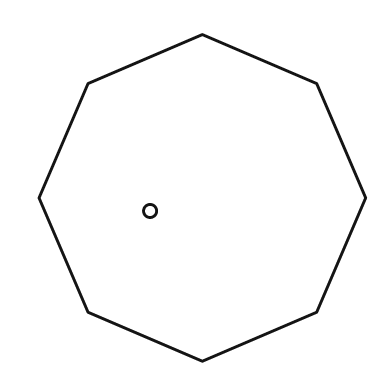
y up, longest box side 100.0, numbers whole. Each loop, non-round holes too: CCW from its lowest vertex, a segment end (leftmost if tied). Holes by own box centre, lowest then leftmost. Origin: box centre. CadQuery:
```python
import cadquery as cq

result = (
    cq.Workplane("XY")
    .moveTo(0.0, -50.0)
    .lineTo(35.0, -35.0)
    .lineTo(50.0, 0.0)
    .lineTo(35.0, 35.0)
    .lineTo(0.0, 50.0)
    .lineTo(-35.0, 35.0)
    .lineTo(-50.0, 0.0)
    .lineTo(-35.0, -35.0)
    .close()
    .moveTo(-16.0, -4.0)
    .circle(2.0)
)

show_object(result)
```